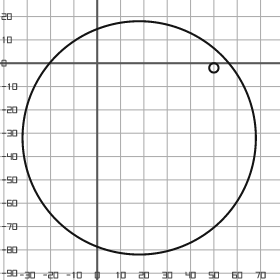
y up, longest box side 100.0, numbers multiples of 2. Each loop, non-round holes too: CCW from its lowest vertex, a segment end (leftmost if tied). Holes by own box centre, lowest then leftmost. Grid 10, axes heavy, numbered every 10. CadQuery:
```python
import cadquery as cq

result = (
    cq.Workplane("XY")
    .moveTo(18.0, -32.0)
    .circle(50.0)
    .moveTo(50.0, -2.0)
    .circle(2.0)
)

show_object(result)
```